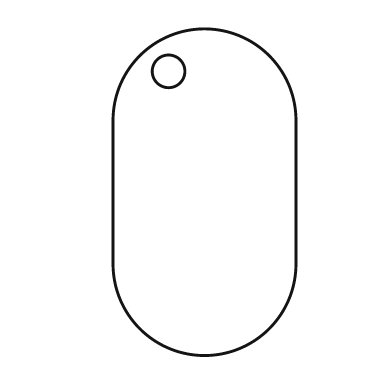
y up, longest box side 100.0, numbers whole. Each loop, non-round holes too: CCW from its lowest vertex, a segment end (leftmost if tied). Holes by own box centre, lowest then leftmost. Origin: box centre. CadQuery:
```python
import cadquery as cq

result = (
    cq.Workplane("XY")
    .moveTo(-28.0, -22.0)
    .threePointArc((0.0, -50.0), (28.0, -22.0))
    .lineTo(28.0, 22.0)
    .threePointArc((0.0, 50.0), (-28.0, 22.0))
    .close()
    .moveTo(-11.0, 37.0)
    .circle(5.0)
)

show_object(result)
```